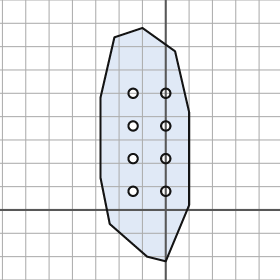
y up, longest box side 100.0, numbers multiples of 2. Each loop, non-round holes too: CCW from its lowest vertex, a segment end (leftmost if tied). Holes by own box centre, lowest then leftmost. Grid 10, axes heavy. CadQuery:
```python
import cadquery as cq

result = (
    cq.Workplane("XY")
    .moveTo(0.0, -22.0)
    .lineTo(10.0, 2.0)
    .lineTo(10.0, 42.0)
    .lineTo(4.0, 68.0)
    .lineTo(-10.0, 78.0)
    .lineTo(-22.0, 74.0)
    .lineTo(-28.0, 48.0)
    .lineTo(-28.0, 14.0)
    .lineTo(-24.0, -6.0)
    .lineTo(-8.0, -20.0)
    .close()
    .moveTo(-14.0, 8.0)
    .circle(2.0)
    .moveTo(0.0, 8.0)
    .circle(2.0)
    .moveTo(-14.0, 22.0)
    .circle(2.0)
    .moveTo(0.0, 22.0)
    .circle(2.0)
    .moveTo(-14.0, 36.0)
    .circle(2.0)
    .moveTo(0.0, 36.0)
    .circle(2.0)
    .moveTo(-14.0, 50.0)
    .circle(2.0)
    .moveTo(0.0, 50.0)
    .circle(2.0)
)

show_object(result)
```